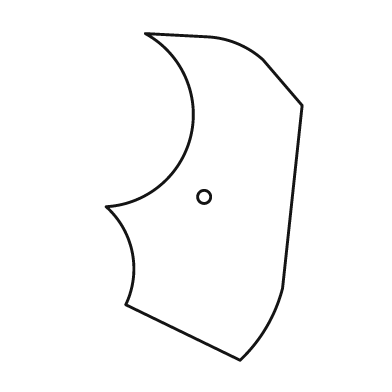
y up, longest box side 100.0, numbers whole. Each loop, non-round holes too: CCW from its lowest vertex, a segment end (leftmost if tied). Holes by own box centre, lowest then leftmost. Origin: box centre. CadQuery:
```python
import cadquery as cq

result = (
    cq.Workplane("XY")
    .moveTo(11.0, -50.0)
    .threePointArc((19.0, -40.0), (24.0, -28.0))
    .lineTo(30.0, 28.0)
    .lineTo(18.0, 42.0)
    .threePointArc((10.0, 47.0), (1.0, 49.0))
    .lineTo(-18.0, 50.0)
    .threePointArc((-4.0, 19.0), (-30.0, -3.0))
    .threePointArc((-22.0, -17.0), (-24.0, -33.0))
    .close()
    .moveTo(0.0, 0.0)
    .circle(2.0)
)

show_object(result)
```